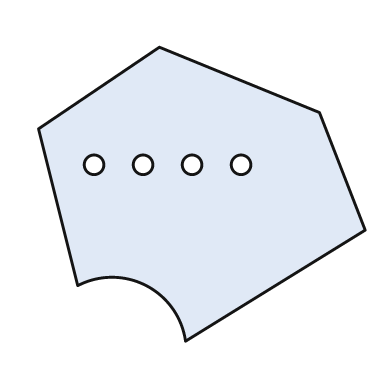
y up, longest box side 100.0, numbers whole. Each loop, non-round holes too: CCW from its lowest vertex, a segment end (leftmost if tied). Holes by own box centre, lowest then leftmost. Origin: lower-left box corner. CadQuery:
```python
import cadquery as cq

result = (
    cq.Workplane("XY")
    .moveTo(45.0, 0.0)
    .lineTo(100.0, 34.0)
    .lineTo(86.0, 70.0)
    .lineTo(37.0, 90.0)
    .lineTo(0.0, 65.0)
    .lineTo(12.0, 17.0)
    .threePointArc((33.0, 17.0), (45.0, 0.0))
    .close()
    .moveTo(17.0, 54.0)
    .circle(3.0)
    .moveTo(32.0, 54.0)
    .circle(3.0)
    .moveTo(47.0, 54.0)
    .circle(3.0)
    .moveTo(62.0, 54.0)
    .circle(3.0)
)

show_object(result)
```